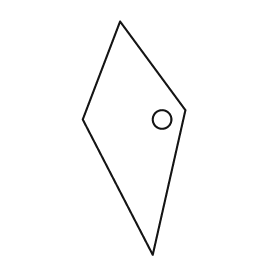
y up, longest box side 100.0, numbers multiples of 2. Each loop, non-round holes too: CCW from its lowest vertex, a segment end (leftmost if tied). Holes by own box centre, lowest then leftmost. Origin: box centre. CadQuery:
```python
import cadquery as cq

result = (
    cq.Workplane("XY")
    .moveTo(8.0, -50.0)
    .lineTo(22.0, 12.0)
    .lineTo(-6.0, 50.0)
    .lineTo(-22.0, 8.0)
    .close()
    .moveTo(12.0, 8.0)
    .circle(4.0)
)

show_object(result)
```